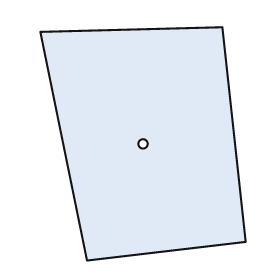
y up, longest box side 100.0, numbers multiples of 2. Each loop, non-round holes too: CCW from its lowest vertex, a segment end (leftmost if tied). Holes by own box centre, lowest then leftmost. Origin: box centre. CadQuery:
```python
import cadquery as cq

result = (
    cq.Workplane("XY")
    .moveTo(-24.0, -50.0)
    .lineTo(44.0, -42.0)
    .lineTo(34.0, 50.0)
    .lineTo(-44.0, 48.0)
    .close()
    .moveTo(0.0, 0.0)
    .circle(2.0)
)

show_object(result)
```